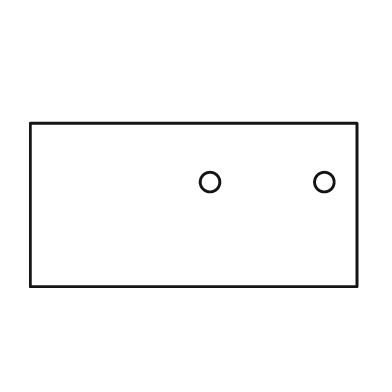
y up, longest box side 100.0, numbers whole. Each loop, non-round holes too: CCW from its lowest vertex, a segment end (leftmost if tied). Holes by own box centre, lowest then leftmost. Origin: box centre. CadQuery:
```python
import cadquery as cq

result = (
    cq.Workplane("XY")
    .moveTo(-50.0, -25.0)
    .lineTo(50.0, -25.0)
    .lineTo(50.0, 25.0)
    .lineTo(-50.0, 25.0)
    .close()
    .moveTo(5.0, 7.0)
    .circle(3.0)
    .moveTo(40.0, 7.0)
    .circle(3.0)
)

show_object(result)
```